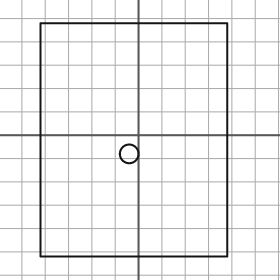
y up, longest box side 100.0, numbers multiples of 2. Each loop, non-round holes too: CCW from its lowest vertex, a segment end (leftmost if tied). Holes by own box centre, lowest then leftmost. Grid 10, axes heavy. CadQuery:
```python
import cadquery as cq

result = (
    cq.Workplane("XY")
    .moveTo(-42.0, -52.0)
    .lineTo(38.0, -52.0)
    .lineTo(38.0, 48.0)
    .lineTo(-42.0, 48.0)
    .close()
    .moveTo(-4.0, -8.0)
    .circle(4.0)
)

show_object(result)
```